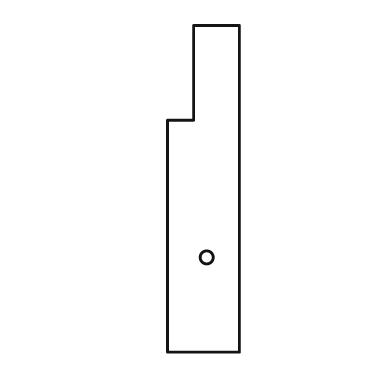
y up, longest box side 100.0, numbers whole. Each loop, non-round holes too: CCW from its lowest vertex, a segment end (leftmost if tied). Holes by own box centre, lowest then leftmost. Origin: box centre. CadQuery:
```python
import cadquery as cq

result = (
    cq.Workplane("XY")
    .moveTo(-11.0, -50.0)
    .lineTo(11.0, -50.0)
    .lineTo(11.0, 50.0)
    .lineTo(-3.0, 50.0)
    .lineTo(-3.0, 21.0)
    .lineTo(-11.0, 21.0)
    .close()
    .moveTo(1.0, -21.0)
    .circle(2.0)
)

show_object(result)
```